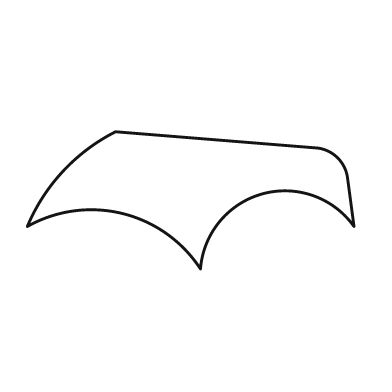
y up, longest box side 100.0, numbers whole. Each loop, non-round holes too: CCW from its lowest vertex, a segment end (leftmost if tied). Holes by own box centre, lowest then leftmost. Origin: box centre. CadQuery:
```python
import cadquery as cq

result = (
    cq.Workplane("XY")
    .moveTo(3.0, -21.0)
    .threePointArc((22.0, 2.0), (50.0, -8.0))
    .lineTo(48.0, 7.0)
    .threePointArc((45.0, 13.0), (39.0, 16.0))
    .lineTo(-23.0, 21.0)
    .threePointArc((-39.0, 9.0), (-50.0, -8.0))
    .threePointArc((-21.0, -4.0), (3.0, -21.0))
    .close()
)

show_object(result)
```